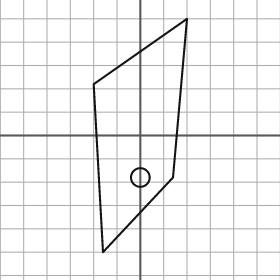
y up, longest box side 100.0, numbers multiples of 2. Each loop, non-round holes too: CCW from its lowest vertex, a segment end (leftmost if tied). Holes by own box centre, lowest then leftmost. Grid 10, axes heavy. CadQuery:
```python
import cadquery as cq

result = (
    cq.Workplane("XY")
    .moveTo(-16.0, -50.0)
    .lineTo(14.0, -18.0)
    .lineTo(20.0, 50.0)
    .lineTo(-20.0, 22.0)
    .close()
    .moveTo(0.0, -18.0)
    .circle(4.0)
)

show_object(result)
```